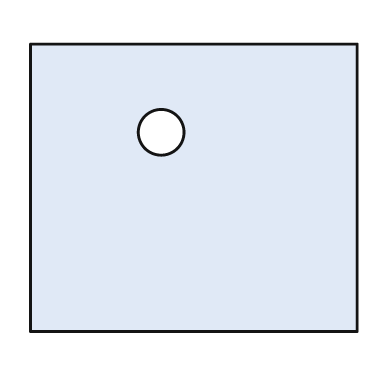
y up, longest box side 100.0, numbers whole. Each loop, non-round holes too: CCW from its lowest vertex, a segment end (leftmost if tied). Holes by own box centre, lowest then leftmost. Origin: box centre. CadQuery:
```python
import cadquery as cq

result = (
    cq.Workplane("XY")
    .moveTo(-50.0, -44.0)
    .lineTo(50.0, -44.0)
    .lineTo(50.0, 44.0)
    .lineTo(-50.0, 44.0)
    .close()
    .moveTo(-10.0, 17.0)
    .circle(7.0)
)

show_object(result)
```